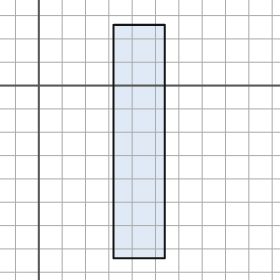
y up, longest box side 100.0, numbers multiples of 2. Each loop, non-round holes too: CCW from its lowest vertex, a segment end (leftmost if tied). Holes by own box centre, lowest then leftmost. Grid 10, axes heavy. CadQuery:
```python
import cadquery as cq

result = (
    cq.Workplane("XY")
    .moveTo(32.0, -74.0)
    .lineTo(54.0, -74.0)
    .lineTo(54.0, 26.0)
    .lineTo(32.0, 26.0)
    .close()
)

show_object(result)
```